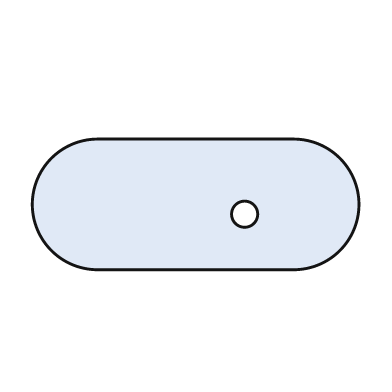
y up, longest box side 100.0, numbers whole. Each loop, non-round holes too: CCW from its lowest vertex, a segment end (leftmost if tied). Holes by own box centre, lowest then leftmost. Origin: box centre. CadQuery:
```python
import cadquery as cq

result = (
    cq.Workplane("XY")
    .moveTo(-30.0, -20.0)
    .lineTo(30.0, -20.0)
    .threePointArc((50.0, 0.0), (30.0, 20.0))
    .lineTo(-30.0, 20.0)
    .threePointArc((-50.0, 0.0), (-30.0, -20.0))
    .close()
    .moveTo(15.0, -3.0)
    .circle(4.0)
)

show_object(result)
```